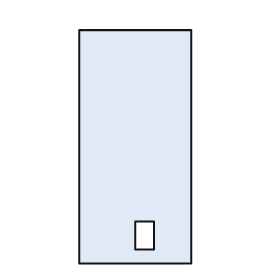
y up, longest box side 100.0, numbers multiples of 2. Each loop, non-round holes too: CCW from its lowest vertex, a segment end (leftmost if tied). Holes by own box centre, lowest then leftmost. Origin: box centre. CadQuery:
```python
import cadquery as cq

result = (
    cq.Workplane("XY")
    .moveTo(-24.0, -50.0)
    .lineTo(24.0, -50.0)
    .lineTo(24.0, 50.0)
    .lineTo(-24.0, 50.0)
    .close()
    .moveTo(0.0, -44.0)
    .lineTo(8.0, -44.0)
    .lineTo(8.0, -32.0)
    .lineTo(0.0, -32.0)
    .close()
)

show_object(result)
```